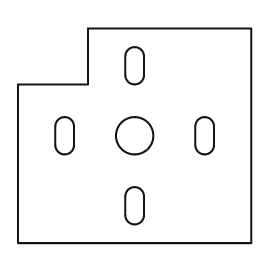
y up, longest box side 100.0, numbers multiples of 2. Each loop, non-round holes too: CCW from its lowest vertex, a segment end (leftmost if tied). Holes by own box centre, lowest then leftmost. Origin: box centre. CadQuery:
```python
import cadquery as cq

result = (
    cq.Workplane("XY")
    .moveTo(-50.0, -46.0)
    .lineTo(50.0, -46.0)
    .lineTo(50.0, 46.0)
    .lineTo(-20.0, 46.0)
    .lineTo(-20.0, 22.0)
    .lineTo(-50.0, 22.0)
    .close()
    .moveTo(-4.0, -34.0)
    .threePointArc((0.0, -38.0), (4.0, -34.0))
    .lineTo(4.0, -26.0)
    .threePointArc((0.0, -22.0), (-4.0, -26.0))
    .close()
    .moveTo(-34.0, -4.0)
    .threePointArc((-30.0, -8.0), (-26.0, -4.0))
    .lineTo(-26.0, 4.0)
    .threePointArc((-30.0, 8.0), (-34.0, 4.0))
    .close()
    .moveTo(0.0, 0.0)
    .circle(8.0)
    .moveTo(26.0, -4.0)
    .threePointArc((30.0, -8.0), (34.0, -4.0))
    .lineTo(34.0, 4.0)
    .threePointArc((30.0, 8.0), (26.0, 4.0))
    .close()
    .moveTo(-4.0, 26.0)
    .threePointArc((0.0, 22.0), (4.0, 26.0))
    .lineTo(4.0, 34.0)
    .threePointArc((0.0, 38.0), (-4.0, 34.0))
    .close()
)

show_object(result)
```